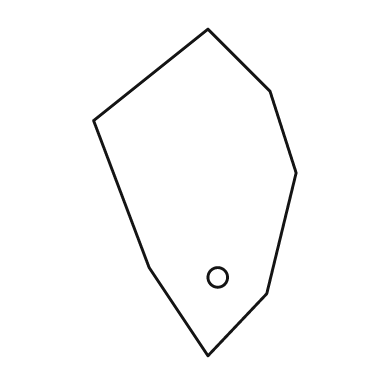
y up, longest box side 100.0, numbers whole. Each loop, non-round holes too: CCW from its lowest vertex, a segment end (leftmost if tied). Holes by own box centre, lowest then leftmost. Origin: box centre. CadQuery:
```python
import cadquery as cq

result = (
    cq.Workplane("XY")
    .moveTo(4.0, -50.0)
    .lineTo(22.0, -31.0)
    .lineTo(31.0, 6.0)
    .lineTo(23.0, 31.0)
    .lineTo(4.0, 50.0)
    .lineTo(-31.0, 22.0)
    .lineTo(-14.0, -23.0)
    .close()
    .moveTo(7.0, -26.0)
    .circle(3.0)
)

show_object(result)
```